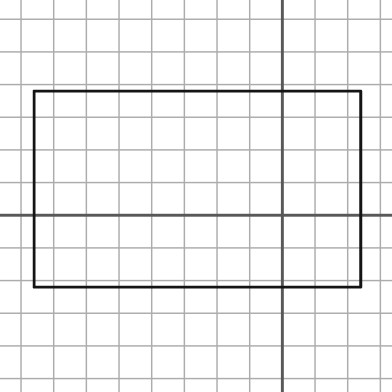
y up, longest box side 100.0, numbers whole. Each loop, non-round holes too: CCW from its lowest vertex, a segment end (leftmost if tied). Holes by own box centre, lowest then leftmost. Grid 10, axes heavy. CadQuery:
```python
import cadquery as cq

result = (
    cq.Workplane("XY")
    .moveTo(-76.0, -22.0)
    .lineTo(24.0, -22.0)
    .lineTo(24.0, 38.0)
    .lineTo(-76.0, 38.0)
    .close()
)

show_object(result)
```